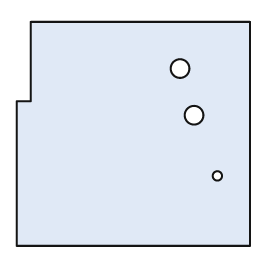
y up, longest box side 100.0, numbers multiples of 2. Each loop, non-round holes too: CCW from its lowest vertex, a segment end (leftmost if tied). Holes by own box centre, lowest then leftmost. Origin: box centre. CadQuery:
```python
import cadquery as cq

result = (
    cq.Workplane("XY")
    .moveTo(-50.0, -48.0)
    .lineTo(50.0, -48.0)
    .lineTo(50.0, 48.0)
    .lineTo(-44.0, 48.0)
    .lineTo(-44.0, 14.0)
    .lineTo(-50.0, 14.0)
    .close()
    .moveTo(36.0, -18.0)
    .circle(2.0)
    .moveTo(26.0, 8.0)
    .circle(4.0)
    .moveTo(20.0, 28.0)
    .circle(4.0)
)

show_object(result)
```